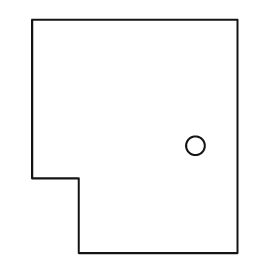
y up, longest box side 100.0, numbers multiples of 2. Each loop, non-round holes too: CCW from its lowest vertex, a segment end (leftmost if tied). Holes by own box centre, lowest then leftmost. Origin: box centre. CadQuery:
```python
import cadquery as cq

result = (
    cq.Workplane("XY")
    .moveTo(-24.0, -50.0)
    .lineTo(44.0, -50.0)
    .lineTo(44.0, 50.0)
    .lineTo(-44.0, 50.0)
    .lineTo(-44.0, -18.0)
    .lineTo(-24.0, -18.0)
    .close()
    .moveTo(26.0, -4.0)
    .circle(4.0)
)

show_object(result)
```